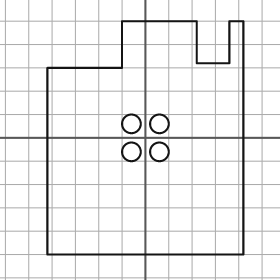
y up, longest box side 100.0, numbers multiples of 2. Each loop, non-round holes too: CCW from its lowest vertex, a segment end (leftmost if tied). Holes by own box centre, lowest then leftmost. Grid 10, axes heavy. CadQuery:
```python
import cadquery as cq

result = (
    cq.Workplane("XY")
    .moveTo(-42.0, -50.0)
    .lineTo(42.0, -50.0)
    .lineTo(42.0, 50.0)
    .lineTo(36.0, 50.0)
    .lineTo(36.0, 32.0)
    .lineTo(22.0, 32.0)
    .lineTo(22.0, 50.0)
    .lineTo(-10.0, 50.0)
    .lineTo(-10.0, 30.0)
    .lineTo(-42.0, 30.0)
    .close()
    .moveTo(-6.0, -6.0)
    .circle(4.0)
    .moveTo(6.0, -6.0)
    .circle(4.0)
    .moveTo(-6.0, 6.0)
    .circle(4.0)
    .moveTo(6.0, 6.0)
    .circle(4.0)
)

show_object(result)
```